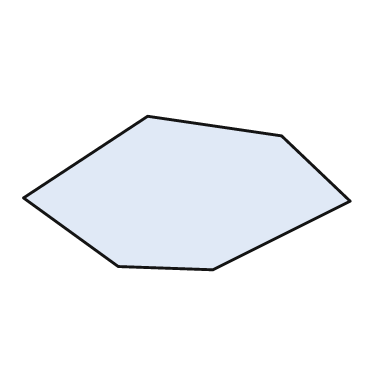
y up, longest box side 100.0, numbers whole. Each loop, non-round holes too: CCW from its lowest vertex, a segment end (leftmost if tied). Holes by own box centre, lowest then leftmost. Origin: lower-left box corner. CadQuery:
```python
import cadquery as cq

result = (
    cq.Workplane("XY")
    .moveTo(58.0, 0.0)
    .lineTo(100.0, 21.0)
    .lineTo(79.0, 41.0)
    .lineTo(38.0, 47.0)
    .lineTo(0.0, 22.0)
    .lineTo(29.0, 1.0)
    .close()
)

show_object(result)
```